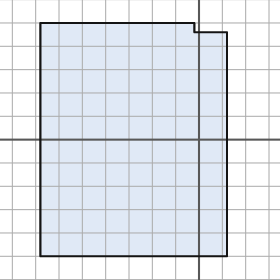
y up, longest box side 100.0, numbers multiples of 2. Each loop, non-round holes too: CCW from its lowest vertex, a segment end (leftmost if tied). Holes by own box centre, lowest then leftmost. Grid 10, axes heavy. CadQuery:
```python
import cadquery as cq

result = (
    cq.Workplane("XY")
    .moveTo(-68.0, -50.0)
    .lineTo(12.0, -50.0)
    .lineTo(12.0, 46.0)
    .lineTo(-2.0, 46.0)
    .lineTo(-2.0, 50.0)
    .lineTo(-68.0, 50.0)
    .close()
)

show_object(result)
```